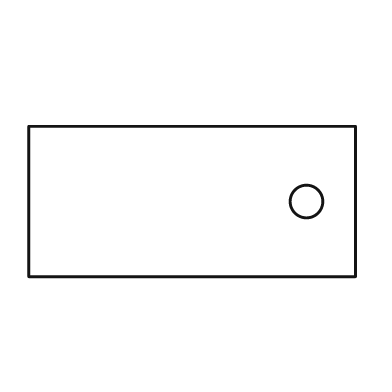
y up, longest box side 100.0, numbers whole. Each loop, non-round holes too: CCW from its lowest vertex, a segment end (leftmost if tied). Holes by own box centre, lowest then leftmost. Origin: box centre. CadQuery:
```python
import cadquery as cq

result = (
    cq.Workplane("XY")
    .moveTo(-50.0, -23.0)
    .lineTo(50.0, -23.0)
    .lineTo(50.0, 23.0)
    .lineTo(-50.0, 23.0)
    .close()
    .moveTo(35.0, 0.0)
    .circle(5.0)
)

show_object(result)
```